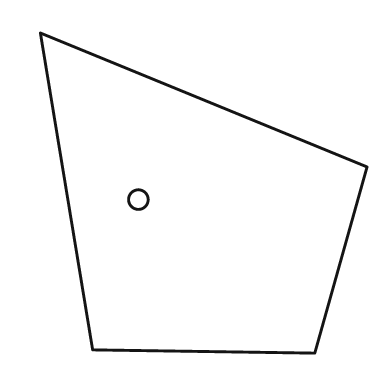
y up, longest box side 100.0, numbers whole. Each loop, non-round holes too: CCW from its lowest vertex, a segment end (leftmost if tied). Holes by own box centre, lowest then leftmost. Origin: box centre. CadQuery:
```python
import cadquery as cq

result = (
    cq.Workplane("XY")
    .moveTo(34.0, -49.0)
    .lineTo(50.0, 8.0)
    .lineTo(-50.0, 49.0)
    .lineTo(-34.0, -48.0)
    .close()
    .moveTo(-20.0, -2.0)
    .circle(3.0)
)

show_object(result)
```